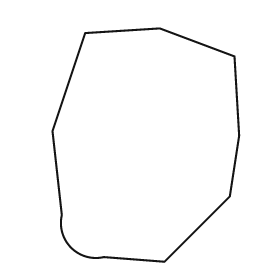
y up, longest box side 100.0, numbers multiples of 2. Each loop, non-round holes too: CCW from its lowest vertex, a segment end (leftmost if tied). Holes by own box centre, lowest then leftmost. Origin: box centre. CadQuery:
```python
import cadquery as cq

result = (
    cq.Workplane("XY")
    .moveTo(8.0, -50.0)
    .lineTo(36.0, -22.0)
    .lineTo(40.0, 4.0)
    .lineTo(38.0, 38.0)
    .lineTo(6.0, 50.0)
    .lineTo(-26.0, 48.0)
    .lineTo(-40.0, 6.0)
    .lineTo(-36.0, -30.0)
    .threePointArc((-32.0, -44.0), (-18.0, -48.0))
    .close()
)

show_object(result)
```